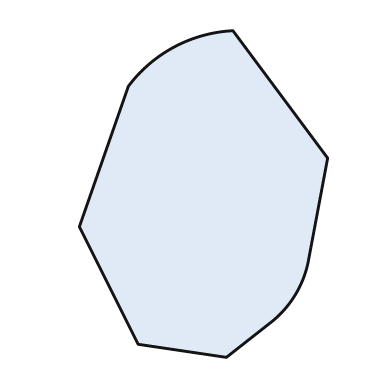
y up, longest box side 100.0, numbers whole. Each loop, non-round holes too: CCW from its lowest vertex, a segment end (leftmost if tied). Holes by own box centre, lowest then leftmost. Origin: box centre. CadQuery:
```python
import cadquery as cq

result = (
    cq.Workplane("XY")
    .moveTo(7.0, -50.0)
    .lineTo(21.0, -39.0)
    .threePointArc((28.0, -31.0), (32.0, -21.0))
    .lineTo(38.0, 11.0)
    .lineTo(9.0, 50.0)
    .threePointArc((-9.0, 45.0), (-23.0, 33.0))
    .lineTo(-38.0, -10.0)
    .lineTo(-20.0, -46.0)
    .close()
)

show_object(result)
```